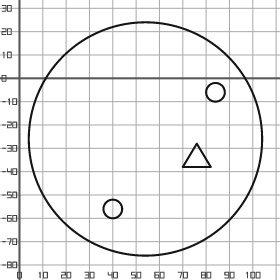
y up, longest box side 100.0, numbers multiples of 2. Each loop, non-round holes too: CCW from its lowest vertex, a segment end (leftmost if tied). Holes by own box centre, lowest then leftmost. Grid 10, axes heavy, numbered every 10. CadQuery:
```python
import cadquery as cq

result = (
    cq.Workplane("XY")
    .moveTo(54.0, -26.0)
    .circle(50.0)
    .moveTo(40.0, -56.0)
    .circle(4.0)
    .moveTo(70.0, -38.0)
    .lineTo(82.0, -38.0)
    .lineTo(76.0, -28.0)
    .close()
    .moveTo(84.0, -6.0)
    .circle(4.0)
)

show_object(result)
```